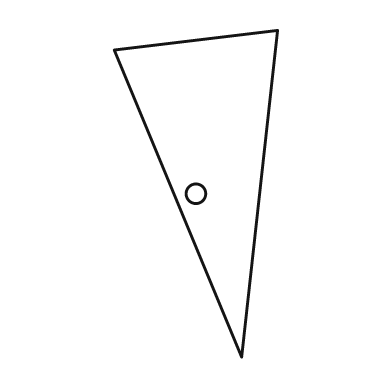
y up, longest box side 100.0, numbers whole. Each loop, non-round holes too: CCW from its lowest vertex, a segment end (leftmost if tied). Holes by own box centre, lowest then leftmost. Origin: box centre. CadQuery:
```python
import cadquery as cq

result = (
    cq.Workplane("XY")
    .moveTo(14.0, -50.0)
    .lineTo(25.0, 50.0)
    .lineTo(-25.0, 44.0)
    .close()
    .moveTo(0.0, 0.0)
    .circle(3.0)
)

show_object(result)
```